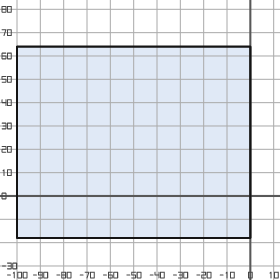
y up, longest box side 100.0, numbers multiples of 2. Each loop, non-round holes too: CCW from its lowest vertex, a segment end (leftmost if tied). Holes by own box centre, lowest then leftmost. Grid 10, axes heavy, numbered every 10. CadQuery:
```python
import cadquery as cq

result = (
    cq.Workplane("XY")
    .moveTo(-100.0, -18.0)
    .lineTo(0.0, -18.0)
    .lineTo(0.0, 64.0)
    .lineTo(-100.0, 64.0)
    .close()
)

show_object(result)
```